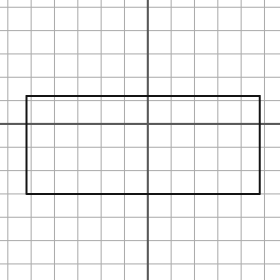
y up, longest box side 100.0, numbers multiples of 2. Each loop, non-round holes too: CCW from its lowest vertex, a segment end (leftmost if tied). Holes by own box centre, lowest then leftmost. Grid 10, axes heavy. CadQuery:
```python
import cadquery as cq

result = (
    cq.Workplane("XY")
    .moveTo(-52.0, -30.0)
    .lineTo(48.0, -30.0)
    .lineTo(48.0, 12.0)
    .lineTo(-52.0, 12.0)
    .close()
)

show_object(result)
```